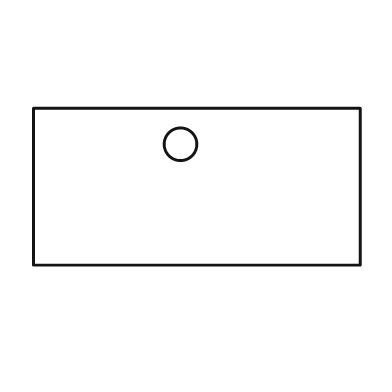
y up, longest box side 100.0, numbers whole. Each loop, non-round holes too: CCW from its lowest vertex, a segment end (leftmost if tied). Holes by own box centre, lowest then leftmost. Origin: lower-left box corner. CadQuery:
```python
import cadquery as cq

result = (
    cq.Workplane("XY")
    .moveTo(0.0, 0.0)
    .lineTo(100.0, 0.0)
    .lineTo(100.0, 48.0)
    .lineTo(0.0, 48.0)
    .close()
    .moveTo(45.0, 37.0)
    .circle(5.0)
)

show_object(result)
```